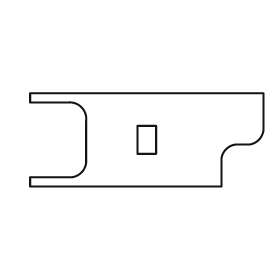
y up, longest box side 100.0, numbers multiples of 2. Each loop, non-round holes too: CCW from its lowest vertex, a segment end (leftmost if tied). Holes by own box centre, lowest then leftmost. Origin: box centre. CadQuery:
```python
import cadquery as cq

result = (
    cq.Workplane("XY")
    .moveTo(-50.0, -20.0)
    .lineTo(32.0, -20.0)
    .lineTo(32.0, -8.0)
    .threePointArc((34.0, -4.0), (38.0, -2.0))
    .lineTo(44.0, -2.0)
    .threePointArc((48.0, 0.0), (50.0, 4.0))
    .lineTo(50.0, 20.0)
    .lineTo(-50.0, 20.0)
    .lineTo(-50.0, 16.0)
    .lineTo(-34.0, 16.0)
    .threePointArc((-28.0, 14.0), (-26.0, 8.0))
    .lineTo(-26.0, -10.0)
    .threePointArc((-28.0, -14.0), (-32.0, -16.0))
    .lineTo(-50.0, -16.0)
    .close()
    .moveTo(-4.0, -6.0)
    .lineTo(4.0, -6.0)
    .lineTo(4.0, 6.0)
    .lineTo(-4.0, 6.0)
    .close()
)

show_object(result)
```